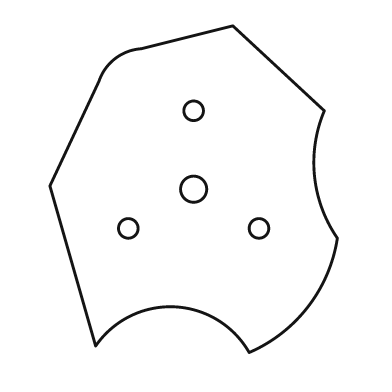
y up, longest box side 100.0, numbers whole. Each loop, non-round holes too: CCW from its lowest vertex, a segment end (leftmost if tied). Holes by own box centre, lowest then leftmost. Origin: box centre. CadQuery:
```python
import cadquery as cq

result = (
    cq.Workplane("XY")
    .moveTo(17.0, -50.0)
    .threePointArc((35.0, -36.0), (44.0, -15.0))
    .threePointArc((37.0, 4.0), (40.0, 24.0))
    .lineTo(12.0, 50.0)
    .lineTo(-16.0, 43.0)
    .threePointArc((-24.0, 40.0), (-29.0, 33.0))
    .lineTo(-44.0, 1.0)
    .lineTo(-30.0, -48.0)
    .threePointArc((-6.0, -36.0), (17.0, -50.0))
    .close()
    .moveTo(-20.0, -12.0)
    .circle(3.0)
    .moveTo(20.0, -12.0)
    .circle(3.0)
    .moveTo(0.0, 0.0)
    .circle(4.0)
    .moveTo(0.0, 24.0)
    .circle(3.0)
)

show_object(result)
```